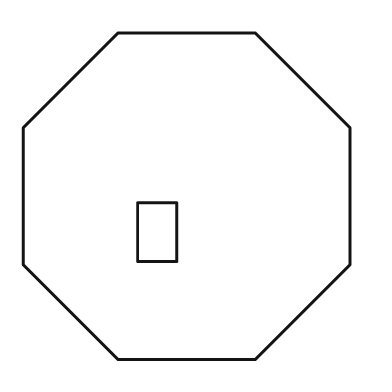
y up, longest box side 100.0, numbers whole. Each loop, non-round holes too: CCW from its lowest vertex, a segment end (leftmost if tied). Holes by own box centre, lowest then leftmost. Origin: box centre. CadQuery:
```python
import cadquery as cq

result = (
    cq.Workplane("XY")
    .moveTo(-21.0, -50.0)
    .lineTo(21.0, -50.0)
    .lineTo(50.0, -21.0)
    .lineTo(50.0, 21.0)
    .lineTo(21.0, 50.0)
    .lineTo(-21.0, 50.0)
    .lineTo(-50.0, 21.0)
    .lineTo(-50.0, -21.0)
    .close()
    .moveTo(-15.0, -20.0)
    .lineTo(-3.0, -20.0)
    .lineTo(-3.0, -2.0)
    .lineTo(-15.0, -2.0)
    .close()
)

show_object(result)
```